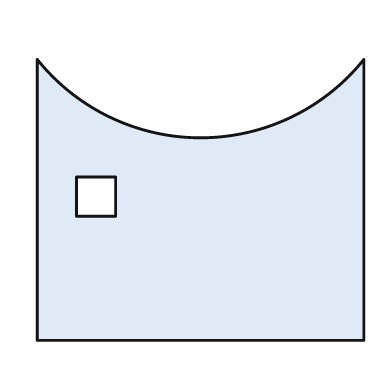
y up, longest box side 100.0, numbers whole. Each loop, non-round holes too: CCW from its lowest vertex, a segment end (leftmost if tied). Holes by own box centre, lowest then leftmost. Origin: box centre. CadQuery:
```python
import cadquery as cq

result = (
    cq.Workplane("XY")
    .moveTo(-50.0, -43.0)
    .lineTo(50.0, -43.0)
    .lineTo(50.0, 43.0)
    .threePointArc((0.0, 19.0), (-50.0, 43.0))
    .close()
    .moveTo(-38.0, -5.0)
    .lineTo(-26.0, -5.0)
    .lineTo(-26.0, 7.0)
    .lineTo(-38.0, 7.0)
    .close()
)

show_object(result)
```